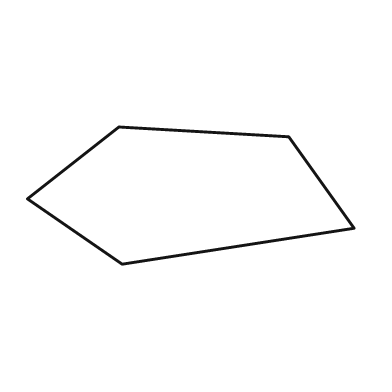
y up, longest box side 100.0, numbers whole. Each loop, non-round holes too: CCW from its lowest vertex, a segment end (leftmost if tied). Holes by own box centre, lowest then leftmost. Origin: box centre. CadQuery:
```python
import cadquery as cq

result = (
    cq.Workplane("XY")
    .moveTo(-21.0, -21.0)
    .lineTo(50.0, -10.0)
    .lineTo(30.0, 18.0)
    .lineTo(-22.0, 21.0)
    .lineTo(-50.0, -1.0)
    .close()
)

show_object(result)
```